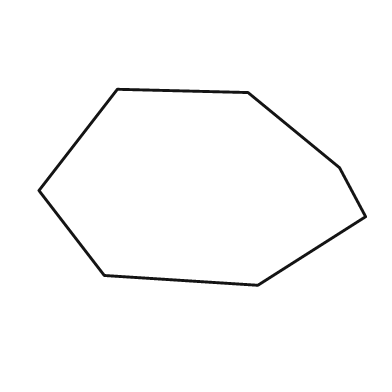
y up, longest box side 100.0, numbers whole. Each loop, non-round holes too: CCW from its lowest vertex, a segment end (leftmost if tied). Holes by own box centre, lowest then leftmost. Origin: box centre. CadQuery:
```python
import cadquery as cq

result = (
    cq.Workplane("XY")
    .moveTo(17.0, -30.0)
    .lineTo(50.0, -9.0)
    .lineTo(42.0, 6.0)
    .lineTo(14.0, 29.0)
    .lineTo(-26.0, 30.0)
    .lineTo(-50.0, -1.0)
    .lineTo(-30.0, -27.0)
    .close()
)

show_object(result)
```